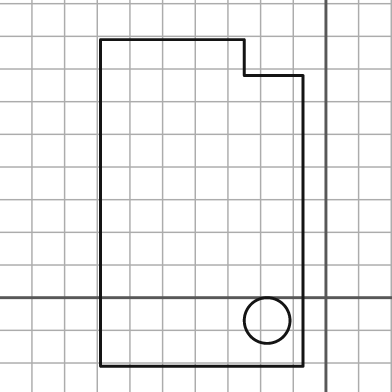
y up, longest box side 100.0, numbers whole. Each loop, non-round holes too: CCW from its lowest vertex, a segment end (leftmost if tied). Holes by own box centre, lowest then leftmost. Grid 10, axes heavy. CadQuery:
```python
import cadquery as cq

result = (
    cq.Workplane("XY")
    .moveTo(-69.0, -21.0)
    .lineTo(-7.0, -21.0)
    .lineTo(-7.0, 68.0)
    .lineTo(-25.0, 68.0)
    .lineTo(-25.0, 79.0)
    .lineTo(-69.0, 79.0)
    .close()
    .moveTo(-18.0, -7.0)
    .circle(7.0)
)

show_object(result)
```